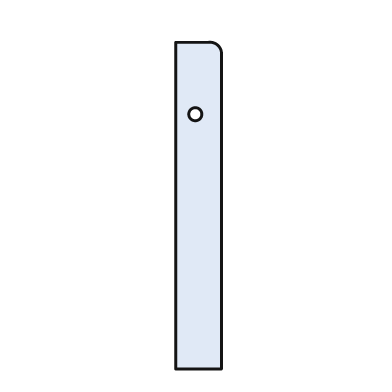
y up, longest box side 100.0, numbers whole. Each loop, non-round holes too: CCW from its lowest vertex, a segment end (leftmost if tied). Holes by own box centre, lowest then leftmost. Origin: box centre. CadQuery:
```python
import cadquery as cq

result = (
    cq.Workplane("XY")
    .moveTo(-7.0, -50.0)
    .lineTo(7.0, -50.0)
    .lineTo(7.0, 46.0)
    .threePointArc((6.0, 49.0), (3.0, 50.0))
    .lineTo(-7.0, 50.0)
    .close()
    .moveTo(-1.0, 28.0)
    .circle(2.0)
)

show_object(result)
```